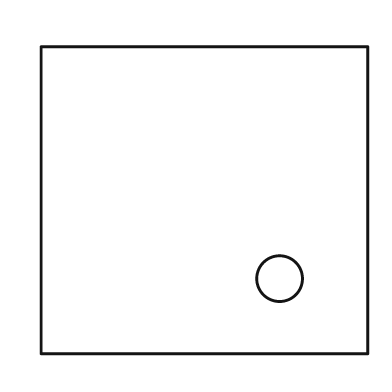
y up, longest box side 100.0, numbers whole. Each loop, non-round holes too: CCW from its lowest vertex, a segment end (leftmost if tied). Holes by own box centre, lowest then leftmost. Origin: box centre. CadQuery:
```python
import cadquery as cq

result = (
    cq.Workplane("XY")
    .moveTo(-50.0, -47.0)
    .lineTo(50.0, -47.0)
    .lineTo(50.0, 47.0)
    .lineTo(-50.0, 47.0)
    .close()
    .moveTo(23.0, -24.0)
    .circle(7.0)
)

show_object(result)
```